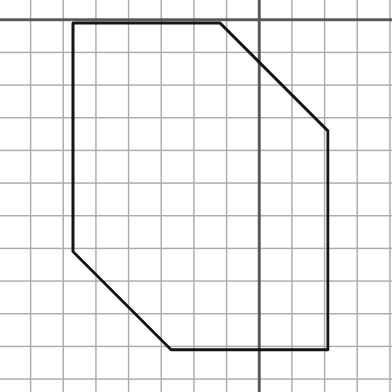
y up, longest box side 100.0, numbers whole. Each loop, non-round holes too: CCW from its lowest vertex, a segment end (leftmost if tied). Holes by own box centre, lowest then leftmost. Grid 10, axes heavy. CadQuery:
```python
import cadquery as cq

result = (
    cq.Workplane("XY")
    .moveTo(-27.0, -101.0)
    .lineTo(21.0, -101.0)
    .lineTo(21.0, -34.0)
    .lineTo(-12.0, -1.0)
    .lineTo(-57.0, -1.0)
    .lineTo(-57.0, -71.0)
    .close()
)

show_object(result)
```